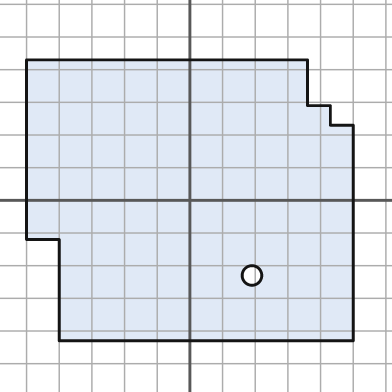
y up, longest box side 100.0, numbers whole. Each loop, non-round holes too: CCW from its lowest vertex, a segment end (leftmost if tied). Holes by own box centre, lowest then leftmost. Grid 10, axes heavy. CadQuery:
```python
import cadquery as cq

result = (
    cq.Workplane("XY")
    .moveTo(-40.0, -43.0)
    .lineTo(50.0, -43.0)
    .lineTo(50.0, 23.0)
    .lineTo(43.0, 23.0)
    .lineTo(43.0, 29.0)
    .lineTo(36.0, 29.0)
    .lineTo(36.0, 43.0)
    .lineTo(-50.0, 43.0)
    .lineTo(-50.0, -12.0)
    .lineTo(-40.0, -12.0)
    .close()
    .moveTo(19.0, -23.0)
    .circle(3.0)
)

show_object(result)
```